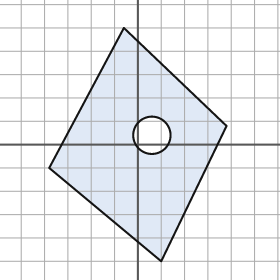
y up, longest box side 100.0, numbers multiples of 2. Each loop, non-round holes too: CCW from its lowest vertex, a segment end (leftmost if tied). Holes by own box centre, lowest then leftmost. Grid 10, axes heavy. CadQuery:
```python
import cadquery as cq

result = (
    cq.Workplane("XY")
    .moveTo(10.0, -50.0)
    .lineTo(38.0, 8.0)
    .lineTo(-6.0, 50.0)
    .lineTo(-38.0, -10.0)
    .close()
    .moveTo(6.0, 4.0)
    .circle(8.0)
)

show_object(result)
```